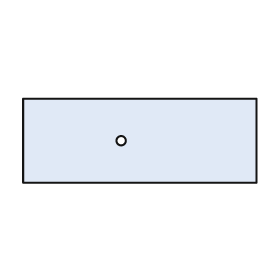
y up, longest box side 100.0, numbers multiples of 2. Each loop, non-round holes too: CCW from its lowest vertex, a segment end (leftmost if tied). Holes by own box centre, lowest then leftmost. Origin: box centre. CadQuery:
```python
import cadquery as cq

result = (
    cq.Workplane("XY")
    .moveTo(-50.0, -18.0)
    .lineTo(50.0, -18.0)
    .lineTo(50.0, 18.0)
    .lineTo(-50.0, 18.0)
    .close()
    .moveTo(-8.0, 0.0)
    .circle(2.0)
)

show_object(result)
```